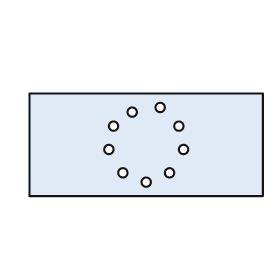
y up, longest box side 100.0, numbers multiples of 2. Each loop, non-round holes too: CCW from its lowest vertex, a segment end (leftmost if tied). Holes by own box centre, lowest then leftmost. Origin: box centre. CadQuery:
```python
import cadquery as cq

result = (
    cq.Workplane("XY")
    .moveTo(-50.0, -22.0)
    .lineTo(50.0, -22.0)
    .lineTo(50.0, 22.0)
    .lineTo(-50.0, 22.0)
    .close()
    .moveTo(0.0, -16.0)
    .circle(2.0)
    .moveTo(-10.0, -12.0)
    .circle(2.0)
    .moveTo(10.0, -12.0)
    .circle(2.0)
    .moveTo(-16.0, -2.0)
    .circle(2.0)
    .moveTo(16.0, -2.0)
    .circle(2.0)
    .moveTo(-14.0, 8.0)
    .circle(2.0)
    .moveTo(14.0, 8.0)
    .circle(2.0)
    .moveTo(-6.0, 14.0)
    .circle(2.0)
    .moveTo(6.0, 16.0)
    .circle(2.0)
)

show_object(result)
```